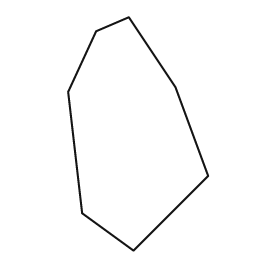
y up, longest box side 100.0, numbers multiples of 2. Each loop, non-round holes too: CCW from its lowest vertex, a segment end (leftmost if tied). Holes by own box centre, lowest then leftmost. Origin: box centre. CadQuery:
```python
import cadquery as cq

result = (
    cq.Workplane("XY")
    .moveTo(-2.0, -50.0)
    .lineTo(30.0, -18.0)
    .lineTo(16.0, 20.0)
    .lineTo(-4.0, 50.0)
    .lineTo(-18.0, 44.0)
    .lineTo(-30.0, 18.0)
    .lineTo(-24.0, -34.0)
    .close()
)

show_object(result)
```